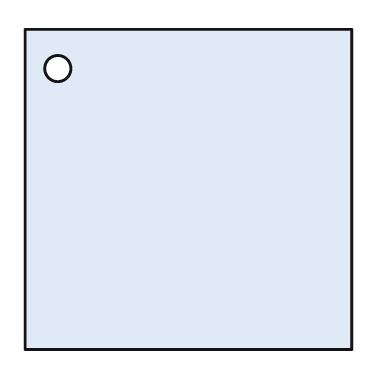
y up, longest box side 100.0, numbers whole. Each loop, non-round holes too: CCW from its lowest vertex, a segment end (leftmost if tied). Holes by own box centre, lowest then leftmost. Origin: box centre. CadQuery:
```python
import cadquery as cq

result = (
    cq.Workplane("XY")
    .moveTo(-50.0, -49.0)
    .lineTo(50.0, -49.0)
    .lineTo(50.0, 49.0)
    .lineTo(-50.0, 49.0)
    .close()
    .moveTo(-40.0, 37.0)
    .circle(4.0)
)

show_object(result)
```